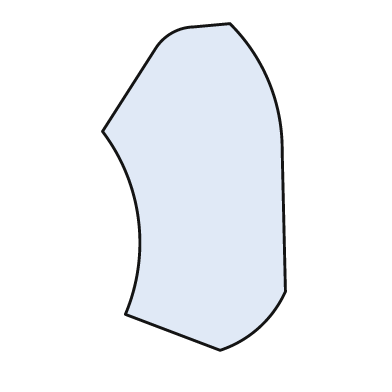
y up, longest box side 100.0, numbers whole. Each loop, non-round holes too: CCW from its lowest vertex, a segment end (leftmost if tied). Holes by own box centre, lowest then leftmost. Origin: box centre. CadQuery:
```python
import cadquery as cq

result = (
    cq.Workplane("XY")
    .moveTo(8.0, -50.0)
    .threePointArc((20.0, -43.0), (28.0, -32.0))
    .lineTo(27.0, 11.0)
    .threePointArc((23.0, 32.0), (11.0, 50.0))
    .lineTo(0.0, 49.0)
    .threePointArc((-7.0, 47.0), (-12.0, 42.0))
    .lineTo(-28.0, 17.0)
    .threePointArc((-17.0, -10.0), (-21.0, -39.0))
    .close()
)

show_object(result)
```